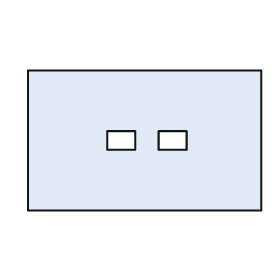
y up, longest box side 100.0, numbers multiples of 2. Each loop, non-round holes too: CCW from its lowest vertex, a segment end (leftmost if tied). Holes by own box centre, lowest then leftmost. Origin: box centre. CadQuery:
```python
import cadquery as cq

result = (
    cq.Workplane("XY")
    .moveTo(-50.0, -30.0)
    .lineTo(50.0, -30.0)
    .lineTo(50.0, 30.0)
    .lineTo(-50.0, 30.0)
    .close()
    .moveTo(-16.0, -4.0)
    .lineTo(-4.0, -4.0)
    .lineTo(-4.0, 4.0)
    .lineTo(-16.0, 4.0)
    .close()
    .moveTo(6.0, -4.0)
    .lineTo(18.0, -4.0)
    .lineTo(18.0, 4.0)
    .lineTo(6.0, 4.0)
    .close()
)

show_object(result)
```